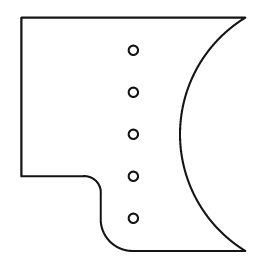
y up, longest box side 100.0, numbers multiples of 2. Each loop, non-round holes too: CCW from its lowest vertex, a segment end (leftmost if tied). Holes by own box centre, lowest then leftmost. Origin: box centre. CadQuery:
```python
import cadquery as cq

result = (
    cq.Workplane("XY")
    .moveTo(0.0, -50.0)
    .lineTo(48.0, -50.0)
    .threePointArc((20.0, 0.0), (48.0, 50.0))
    .lineTo(-48.0, 50.0)
    .lineTo(-48.0, -18.0)
    .lineTo(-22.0, -18.0)
    .threePointArc((-16.0, -20.0), (-14.0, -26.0))
    .lineTo(-14.0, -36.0)
    .threePointArc((-10.0, -46.0), (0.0, -50.0))
    .close()
    .moveTo(0.0, -36.0)
    .circle(2.0)
    .moveTo(0.0, -18.0)
    .circle(2.0)
    .moveTo(0.0, 0.0)
    .circle(2.0)
    .moveTo(0.0, 18.0)
    .circle(2.0)
    .moveTo(0.0, 36.0)
    .circle(2.0)
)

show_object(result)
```